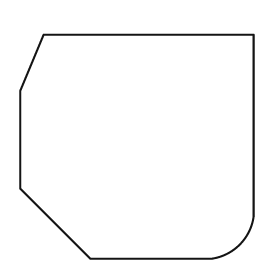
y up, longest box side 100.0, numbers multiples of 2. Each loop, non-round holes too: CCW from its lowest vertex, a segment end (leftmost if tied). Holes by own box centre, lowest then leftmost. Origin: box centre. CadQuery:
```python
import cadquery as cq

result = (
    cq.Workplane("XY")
    .moveTo(-20.0, -48.0)
    .lineTo(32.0, -48.0)
    .threePointArc((44.0, -42.0), (50.0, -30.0))
    .lineTo(50.0, 48.0)
    .lineTo(-40.0, 48.0)
    .lineTo(-50.0, 24.0)
    .lineTo(-50.0, -18.0)
    .close()
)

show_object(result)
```